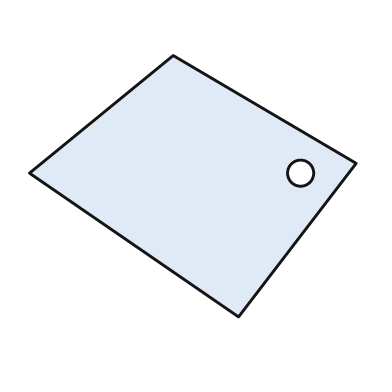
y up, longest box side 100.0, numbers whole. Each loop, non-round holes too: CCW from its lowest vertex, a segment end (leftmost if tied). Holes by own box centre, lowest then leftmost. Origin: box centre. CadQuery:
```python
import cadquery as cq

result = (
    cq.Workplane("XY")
    .moveTo(14.0, -40.0)
    .lineTo(50.0, 7.0)
    .lineTo(-6.0, 40.0)
    .lineTo(-50.0, 4.0)
    .close()
    .moveTo(33.0, 4.0)
    .circle(4.0)
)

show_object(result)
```